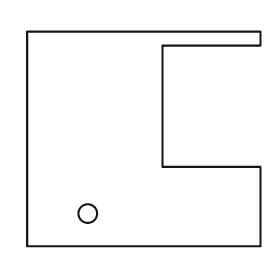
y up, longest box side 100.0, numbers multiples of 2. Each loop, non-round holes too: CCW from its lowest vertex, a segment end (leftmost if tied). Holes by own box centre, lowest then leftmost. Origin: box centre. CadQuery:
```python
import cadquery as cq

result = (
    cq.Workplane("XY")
    .moveTo(-50.0, -46.0)
    .lineTo(50.0, -46.0)
    .lineTo(50.0, -12.0)
    .lineTo(8.0, -12.0)
    .lineTo(8.0, 40.0)
    .lineTo(50.0, 40.0)
    .lineTo(50.0, 46.0)
    .lineTo(-50.0, 46.0)
    .close()
    .moveTo(-24.0, -32.0)
    .circle(4.0)
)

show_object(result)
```